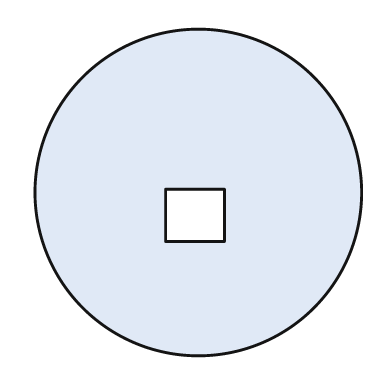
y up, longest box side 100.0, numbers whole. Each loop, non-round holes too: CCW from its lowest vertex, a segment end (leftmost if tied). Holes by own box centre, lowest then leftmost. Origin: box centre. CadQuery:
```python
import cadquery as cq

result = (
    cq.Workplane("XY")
    .moveTo(0.0, 0.0)
    .circle(50.0)
    .moveTo(-10.0, -15.0)
    .lineTo(8.0, -15.0)
    .lineTo(8.0, 1.0)
    .lineTo(-10.0, 1.0)
    .close()
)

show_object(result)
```